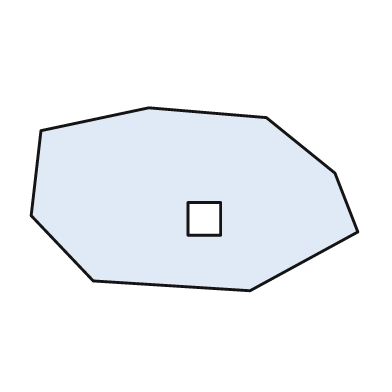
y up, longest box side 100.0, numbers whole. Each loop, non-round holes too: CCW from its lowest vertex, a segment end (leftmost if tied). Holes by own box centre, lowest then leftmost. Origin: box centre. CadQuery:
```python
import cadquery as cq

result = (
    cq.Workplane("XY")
    .moveTo(17.0, -28.0)
    .lineTo(50.0, -10.0)
    .lineTo(43.0, 8.0)
    .lineTo(22.0, 25.0)
    .lineTo(-14.0, 28.0)
    .lineTo(-47.0, 21.0)
    .lineTo(-50.0, -5.0)
    .lineTo(-31.0, -25.0)
    .close()
    .moveTo(-2.0, -11.0)
    .lineTo(8.0, -11.0)
    .lineTo(8.0, -1.0)
    .lineTo(-2.0, -1.0)
    .close()
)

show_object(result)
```